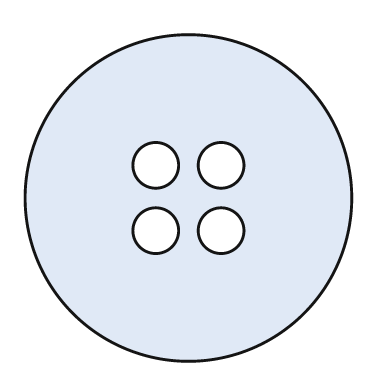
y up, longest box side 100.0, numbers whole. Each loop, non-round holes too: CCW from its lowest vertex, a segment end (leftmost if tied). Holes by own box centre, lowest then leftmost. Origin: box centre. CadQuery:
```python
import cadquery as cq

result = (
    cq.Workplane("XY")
    .moveTo(0.0, 0.0)
    .circle(50.0)
    .moveTo(-10.0, -10.0)
    .circle(7.0)
    .moveTo(10.0, -10.0)
    .circle(7.0)
    .moveTo(-10.0, 10.0)
    .circle(7.0)
    .moveTo(10.0, 10.0)
    .circle(7.0)
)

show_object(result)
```